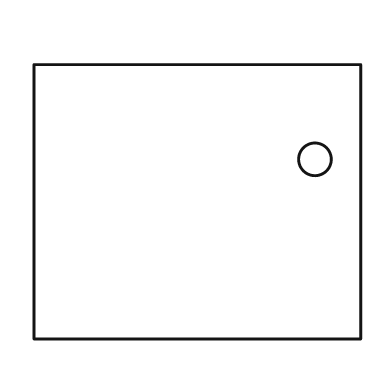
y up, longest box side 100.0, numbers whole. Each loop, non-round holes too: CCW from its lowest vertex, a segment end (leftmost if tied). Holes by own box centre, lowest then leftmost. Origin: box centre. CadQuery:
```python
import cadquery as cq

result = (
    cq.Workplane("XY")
    .moveTo(-50.0, -42.0)
    .lineTo(50.0, -42.0)
    .lineTo(50.0, 42.0)
    .lineTo(-50.0, 42.0)
    .close()
    .moveTo(36.0, 13.0)
    .circle(5.0)
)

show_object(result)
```